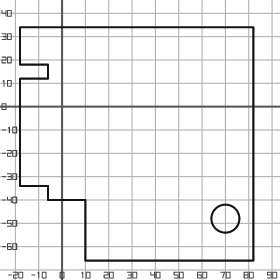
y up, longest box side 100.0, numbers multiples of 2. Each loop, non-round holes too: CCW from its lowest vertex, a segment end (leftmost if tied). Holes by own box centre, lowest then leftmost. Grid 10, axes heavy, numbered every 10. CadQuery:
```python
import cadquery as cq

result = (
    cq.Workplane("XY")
    .moveTo(10.0, -66.0)
    .lineTo(82.0, -66.0)
    .lineTo(82.0, 34.0)
    .lineTo(-18.0, 34.0)
    .lineTo(-18.0, 18.0)
    .lineTo(-6.0, 18.0)
    .lineTo(-6.0, 12.0)
    .lineTo(-18.0, 12.0)
    .lineTo(-18.0, -34.0)
    .lineTo(-6.0, -34.0)
    .lineTo(-6.0, -40.0)
    .lineTo(10.0, -40.0)
    .close()
    .moveTo(70.0, -48.0)
    .circle(6.0)
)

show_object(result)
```